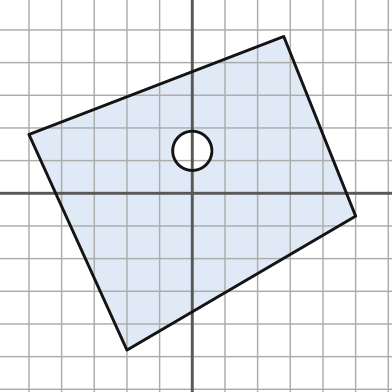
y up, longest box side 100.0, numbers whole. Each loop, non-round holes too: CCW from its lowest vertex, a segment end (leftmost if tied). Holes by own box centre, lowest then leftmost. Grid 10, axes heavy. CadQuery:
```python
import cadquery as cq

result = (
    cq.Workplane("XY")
    .moveTo(-20.0, -48.0)
    .lineTo(50.0, -7.0)
    .lineTo(28.0, 48.0)
    .lineTo(-50.0, 18.0)
    .close()
    .moveTo(0.0, 13.0)
    .circle(6.0)
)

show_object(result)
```